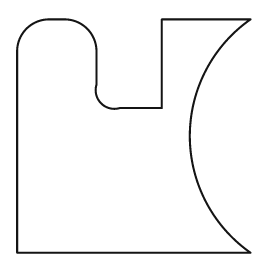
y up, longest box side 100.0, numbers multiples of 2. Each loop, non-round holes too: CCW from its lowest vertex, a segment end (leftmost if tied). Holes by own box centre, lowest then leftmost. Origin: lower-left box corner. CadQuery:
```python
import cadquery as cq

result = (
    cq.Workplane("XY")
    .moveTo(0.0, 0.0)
    .lineTo(100.0, 0.0)
    .threePointArc((74.0, 50.0), (100.0, 100.0))
    .lineTo(62.0, 100.0)
    .lineTo(62.0, 62.0)
    .lineTo(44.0, 62.0)
    .threePointArc((36.0, 64.0), (34.0, 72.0))
    .lineTo(34.0, 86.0)
    .threePointArc((30.0, 96.0), (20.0, 100.0))
    .lineTo(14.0, 100.0)
    .threePointArc((4.0, 96.0), (0.0, 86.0))
    .close()
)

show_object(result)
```